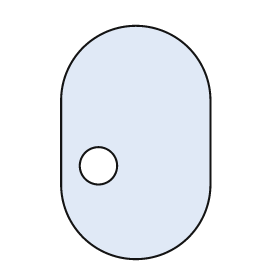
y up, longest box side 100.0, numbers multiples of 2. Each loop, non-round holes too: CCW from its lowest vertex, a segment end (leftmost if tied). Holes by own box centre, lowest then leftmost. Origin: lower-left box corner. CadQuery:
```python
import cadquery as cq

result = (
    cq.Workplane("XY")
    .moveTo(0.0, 32.0)
    .threePointArc((32.0, 0.0), (64.0, 32.0))
    .lineTo(64.0, 68.0)
    .threePointArc((32.0, 100.0), (0.0, 68.0))
    .close()
    .moveTo(16.0, 40.0)
    .circle(8.0)
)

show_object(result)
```